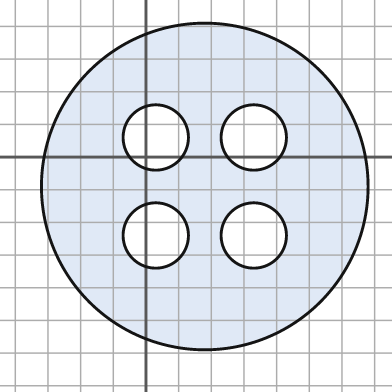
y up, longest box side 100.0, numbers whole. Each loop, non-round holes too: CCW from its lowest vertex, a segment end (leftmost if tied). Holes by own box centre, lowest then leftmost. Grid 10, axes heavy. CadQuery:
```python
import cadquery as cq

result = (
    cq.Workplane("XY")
    .moveTo(18.0, -9.0)
    .circle(50.0)
    .moveTo(3.0, -24.0)
    .circle(10.0)
    .moveTo(33.0, -24.0)
    .circle(10.0)
    .moveTo(3.0, 6.0)
    .circle(10.0)
    .moveTo(33.0, 6.0)
    .circle(10.0)
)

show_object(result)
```